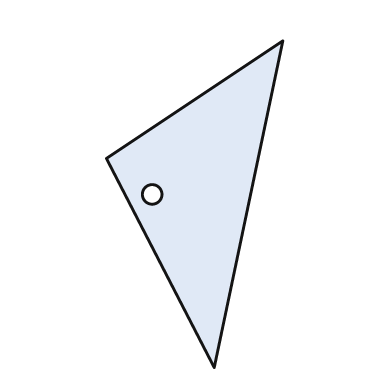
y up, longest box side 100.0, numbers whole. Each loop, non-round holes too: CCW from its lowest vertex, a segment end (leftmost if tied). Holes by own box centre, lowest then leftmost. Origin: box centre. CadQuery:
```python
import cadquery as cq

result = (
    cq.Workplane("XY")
    .moveTo(6.0, -50.0)
    .lineTo(27.0, 50.0)
    .lineTo(-27.0, 14.0)
    .close()
    .moveTo(-13.0, 3.0)
    .circle(3.0)
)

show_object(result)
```